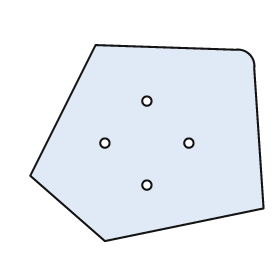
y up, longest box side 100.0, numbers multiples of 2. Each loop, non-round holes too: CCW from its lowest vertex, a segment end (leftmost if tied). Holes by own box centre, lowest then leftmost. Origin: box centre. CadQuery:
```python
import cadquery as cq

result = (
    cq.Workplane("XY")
    .moveTo(-18.0, -42.0)
    .lineTo(50.0, -28.0)
    .lineTo(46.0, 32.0)
    .threePointArc((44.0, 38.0), (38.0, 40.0))
    .lineTo(-22.0, 42.0)
    .lineTo(-50.0, -14.0)
    .close()
    .moveTo(0.0, -18.0)
    .circle(2.0)
    .moveTo(-18.0, 0.0)
    .circle(2.0)
    .moveTo(18.0, 0.0)
    .circle(2.0)
    .moveTo(0.0, 18.0)
    .circle(2.0)
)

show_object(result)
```